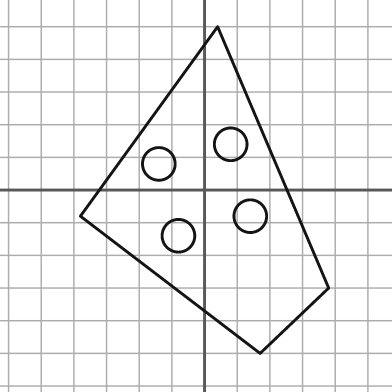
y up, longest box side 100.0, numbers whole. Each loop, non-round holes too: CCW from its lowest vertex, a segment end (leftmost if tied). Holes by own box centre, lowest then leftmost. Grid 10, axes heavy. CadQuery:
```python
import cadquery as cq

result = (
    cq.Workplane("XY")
    .moveTo(17.0, -50.0)
    .lineTo(38.0, -30.0)
    .lineTo(4.0, 50.0)
    .lineTo(-38.0, -8.0)
    .close()
    .moveTo(-8.0, -14.0)
    .circle(5.0)
    .moveTo(14.0, -8.0)
    .circle(5.0)
    .moveTo(-14.0, 8.0)
    .circle(5.0)
    .moveTo(8.0, 14.0)
    .circle(5.0)
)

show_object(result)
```